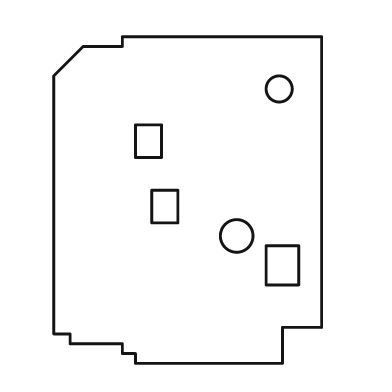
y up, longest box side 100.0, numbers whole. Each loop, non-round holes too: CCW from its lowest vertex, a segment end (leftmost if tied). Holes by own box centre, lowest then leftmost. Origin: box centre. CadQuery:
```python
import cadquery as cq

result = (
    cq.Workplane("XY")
    .moveTo(-16.0, -50.0)
    .lineTo(29.0, -50.0)
    .lineTo(29.0, -39.0)
    .lineTo(41.0, -39.0)
    .lineTo(41.0, 50.0)
    .lineTo(-20.0, 50.0)
    .lineTo(-20.0, 47.0)
    .lineTo(-32.0, 47.0)
    .lineTo(-41.0, 38.0)
    .lineTo(-41.0, -41.0)
    .lineTo(-36.0, -41.0)
    .lineTo(-36.0, -44.0)
    .lineTo(-20.0, -44.0)
    .lineTo(-20.0, -47.0)
    .lineTo(-16.0, -47.0)
    .close()
    .moveTo(24.0, -26.0)
    .lineTo(34.0, -26.0)
    .lineTo(34.0, -14.0)
    .lineTo(24.0, -14.0)
    .close()
    .moveTo(15.0, -11.0)
    .circle(5.0)
    .moveTo(-11.0, -7.0)
    .lineTo(-3.0, -7.0)
    .lineTo(-3.0, 3.0)
    .lineTo(-11.0, 3.0)
    .close()
    .moveTo(-16.0, 13.0)
    .lineTo(-8.0, 13.0)
    .lineTo(-8.0, 23.0)
    .lineTo(-16.0, 23.0)
    .close()
    .moveTo(28.0, 34.0)
    .circle(4.0)
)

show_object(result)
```